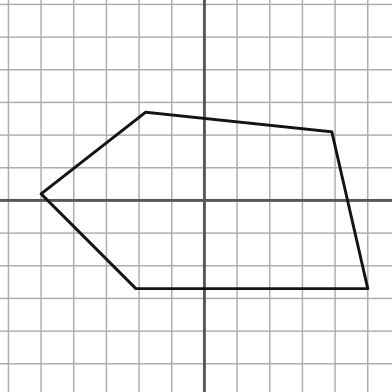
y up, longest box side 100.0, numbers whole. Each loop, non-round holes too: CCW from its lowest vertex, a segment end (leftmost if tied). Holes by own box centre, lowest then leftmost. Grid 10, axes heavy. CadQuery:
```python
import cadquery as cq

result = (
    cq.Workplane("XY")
    .moveTo(-21.0, -27.0)
    .lineTo(50.0, -27.0)
    .lineTo(39.0, 21.0)
    .lineTo(-18.0, 27.0)
    .lineTo(-50.0, 2.0)
    .close()
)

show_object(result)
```